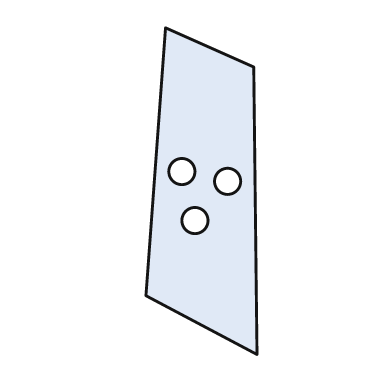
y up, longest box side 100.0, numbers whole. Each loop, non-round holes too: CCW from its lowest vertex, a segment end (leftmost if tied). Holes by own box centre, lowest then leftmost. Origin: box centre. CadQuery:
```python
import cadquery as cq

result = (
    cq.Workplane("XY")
    .moveTo(17.0, -50.0)
    .lineTo(16.0, 38.0)
    .lineTo(-11.0, 50.0)
    .lineTo(-17.0, -32.0)
    .close()
    .moveTo(-2.0, -9.0)
    .circle(4.0)
    .moveTo(8.0, 3.0)
    .circle(4.0)
    .moveTo(-6.0, 6.0)
    .circle(4.0)
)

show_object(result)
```